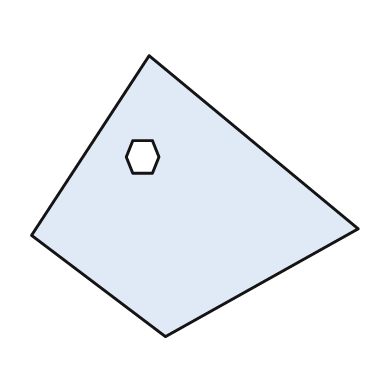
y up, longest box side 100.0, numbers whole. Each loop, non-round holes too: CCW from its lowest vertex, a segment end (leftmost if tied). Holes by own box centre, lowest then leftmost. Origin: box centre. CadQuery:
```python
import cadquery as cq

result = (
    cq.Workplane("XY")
    .moveTo(-9.0, -43.0)
    .lineTo(50.0, -10.0)
    .lineTo(-14.0, 43.0)
    .lineTo(-50.0, -12.0)
    .close()
    .moveTo(-19.0, 7.0)
    .lineTo(-13.0, 7.0)
    .lineTo(-11.0, 12.0)
    .lineTo(-13.0, 17.0)
    .lineTo(-19.0, 17.0)
    .lineTo(-21.0, 12.0)
    .close()
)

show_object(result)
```